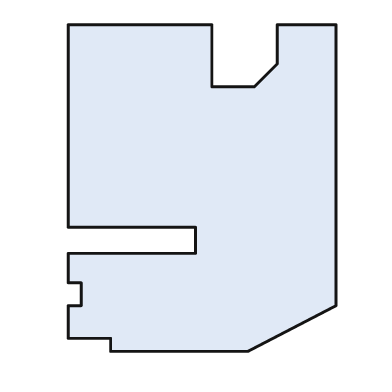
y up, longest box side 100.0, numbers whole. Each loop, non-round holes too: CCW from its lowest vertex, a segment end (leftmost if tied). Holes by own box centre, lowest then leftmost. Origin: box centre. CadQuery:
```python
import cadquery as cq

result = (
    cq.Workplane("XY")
    .moveTo(-28.0, -50.0)
    .lineTo(14.0, -50.0)
    .lineTo(41.0, -36.0)
    .lineTo(41.0, 50.0)
    .lineTo(23.0, 50.0)
    .lineTo(23.0, 38.0)
    .lineTo(16.0, 31.0)
    .lineTo(3.0, 31.0)
    .lineTo(3.0, 50.0)
    .lineTo(-41.0, 50.0)
    .lineTo(-41.0, -12.0)
    .lineTo(-2.0, -12.0)
    .lineTo(-2.0, -20.0)
    .lineTo(-41.0, -20.0)
    .lineTo(-41.0, -29.0)
    .lineTo(-37.0, -29.0)
    .lineTo(-37.0, -36.0)
    .lineTo(-41.0, -36.0)
    .lineTo(-41.0, -46.0)
    .lineTo(-28.0, -46.0)
    .close()
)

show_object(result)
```